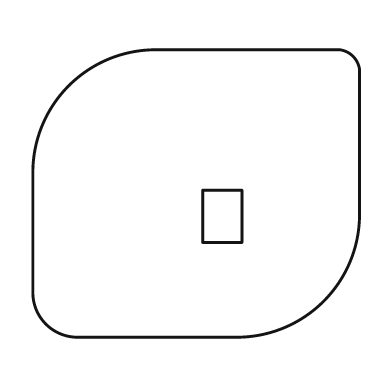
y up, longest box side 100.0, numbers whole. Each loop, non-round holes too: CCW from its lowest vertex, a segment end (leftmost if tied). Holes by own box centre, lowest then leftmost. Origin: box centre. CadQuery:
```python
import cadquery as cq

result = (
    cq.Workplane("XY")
    .moveTo(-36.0, -44.0)
    .lineTo(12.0, -44.0)
    .threePointArc((39.0, -33.0), (50.0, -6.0))
    .lineTo(50.0, 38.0)
    .threePointArc((48.0, 42.0), (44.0, 44.0))
    .lineTo(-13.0, 44.0)
    .threePointArc((-39.0, 33.0), (-50.0, 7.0))
    .lineTo(-50.0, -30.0)
    .threePointArc((-46.0, -40.0), (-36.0, -44.0))
    .close()
    .moveTo(2.0, -15.0)
    .lineTo(14.0, -15.0)
    .lineTo(14.0, 1.0)
    .lineTo(2.0, 1.0)
    .close()
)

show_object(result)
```